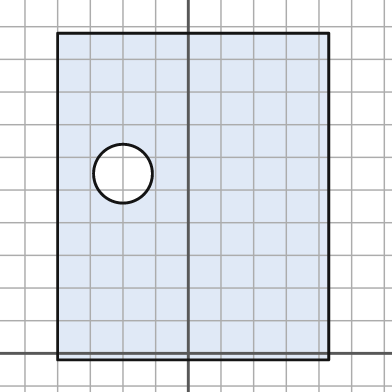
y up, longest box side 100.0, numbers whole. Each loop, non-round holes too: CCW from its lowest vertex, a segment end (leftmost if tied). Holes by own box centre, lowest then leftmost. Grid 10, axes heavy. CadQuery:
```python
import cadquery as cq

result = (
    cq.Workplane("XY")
    .moveTo(-40.0, -2.0)
    .lineTo(43.0, -2.0)
    .lineTo(43.0, 98.0)
    .lineTo(-40.0, 98.0)
    .close()
    .moveTo(-20.0, 55.0)
    .circle(9.0)
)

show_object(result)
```